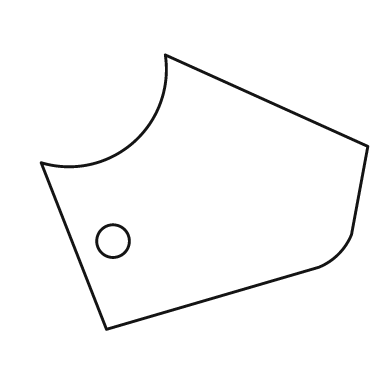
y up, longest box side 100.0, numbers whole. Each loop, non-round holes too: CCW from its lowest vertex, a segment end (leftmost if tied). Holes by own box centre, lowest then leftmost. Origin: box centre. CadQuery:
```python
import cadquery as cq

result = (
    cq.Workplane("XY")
    .moveTo(-30.0, -42.0)
    .lineTo(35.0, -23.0)
    .threePointArc((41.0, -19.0), (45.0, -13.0))
    .lineTo(50.0, 14.0)
    .lineTo(-12.0, 42.0)
    .threePointArc((-22.0, 15.0), (-50.0, 9.0))
    .close()
    .moveTo(-28.0, -15.0)
    .circle(5.0)
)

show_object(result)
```